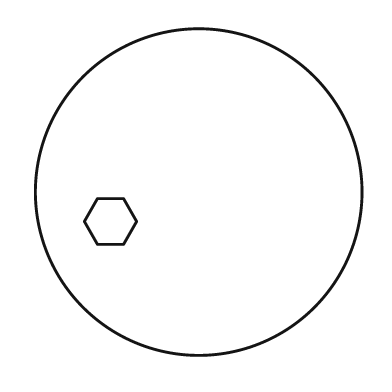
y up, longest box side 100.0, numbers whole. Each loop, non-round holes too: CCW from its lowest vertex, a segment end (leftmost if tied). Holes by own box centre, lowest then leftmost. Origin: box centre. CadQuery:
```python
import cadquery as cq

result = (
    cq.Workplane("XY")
    .moveTo(0.0, 0.0)
    .circle(50.0)
    .moveTo(-31.0, -16.0)
    .lineTo(-23.0, -16.0)
    .lineTo(-19.0, -9.0)
    .lineTo(-23.0, -2.0)
    .lineTo(-31.0, -2.0)
    .lineTo(-35.0, -9.0)
    .close()
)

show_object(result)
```